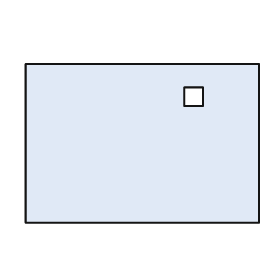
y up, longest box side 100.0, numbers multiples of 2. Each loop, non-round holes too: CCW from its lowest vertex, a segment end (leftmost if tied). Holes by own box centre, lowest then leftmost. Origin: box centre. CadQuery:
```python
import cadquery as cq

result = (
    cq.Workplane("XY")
    .moveTo(-50.0, -34.0)
    .lineTo(50.0, -34.0)
    .lineTo(50.0, 34.0)
    .lineTo(-50.0, 34.0)
    .close()
    .moveTo(18.0, 16.0)
    .lineTo(26.0, 16.0)
    .lineTo(26.0, 24.0)
    .lineTo(18.0, 24.0)
    .close()
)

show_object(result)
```